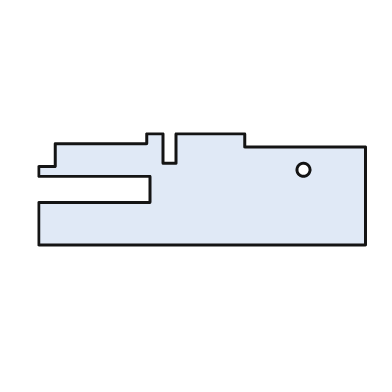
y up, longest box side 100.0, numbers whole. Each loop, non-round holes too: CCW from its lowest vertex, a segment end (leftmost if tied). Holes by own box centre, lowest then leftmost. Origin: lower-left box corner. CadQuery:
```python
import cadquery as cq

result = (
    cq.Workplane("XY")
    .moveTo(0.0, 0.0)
    .lineTo(100.0, 0.0)
    .lineTo(100.0, 30.0)
    .lineTo(63.0, 30.0)
    .lineTo(63.0, 34.0)
    .lineTo(42.0, 34.0)
    .lineTo(42.0, 25.0)
    .lineTo(38.0, 25.0)
    .lineTo(38.0, 34.0)
    .lineTo(33.0, 34.0)
    .lineTo(33.0, 31.0)
    .lineTo(5.0, 31.0)
    .lineTo(5.0, 24.0)
    .lineTo(0.0, 24.0)
    .lineTo(0.0, 21.0)
    .lineTo(34.0, 21.0)
    .lineTo(34.0, 13.0)
    .lineTo(0.0, 13.0)
    .close()
    .moveTo(81.0, 23.0)
    .circle(2.0)
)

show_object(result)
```